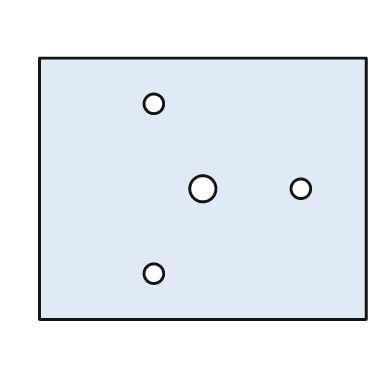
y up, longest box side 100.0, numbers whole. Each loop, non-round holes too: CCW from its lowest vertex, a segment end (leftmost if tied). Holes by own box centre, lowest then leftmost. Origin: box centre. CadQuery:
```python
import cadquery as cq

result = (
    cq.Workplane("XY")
    .moveTo(-50.0, -40.0)
    .lineTo(50.0, -40.0)
    .lineTo(50.0, 40.0)
    .lineTo(-50.0, 40.0)
    .close()
    .moveTo(-15.0, -26.0)
    .circle(3.0)
    .moveTo(0.0, 0.0)
    .circle(4.0)
    .moveTo(30.0, 0.0)
    .circle(3.0)
    .moveTo(-15.0, 26.0)
    .circle(3.0)
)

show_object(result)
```